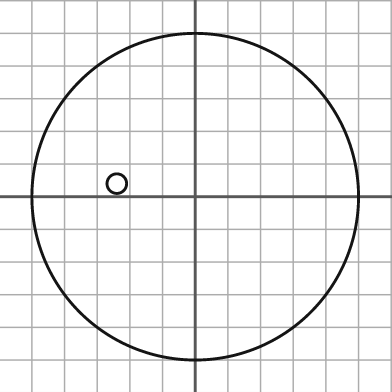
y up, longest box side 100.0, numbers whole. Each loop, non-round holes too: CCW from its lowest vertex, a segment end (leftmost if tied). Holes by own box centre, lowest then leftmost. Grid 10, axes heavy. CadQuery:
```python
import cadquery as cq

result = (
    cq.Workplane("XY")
    .moveTo(0.0, 0.0)
    .circle(50.0)
    .moveTo(-24.0, 4.0)
    .circle(3.0)
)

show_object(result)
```